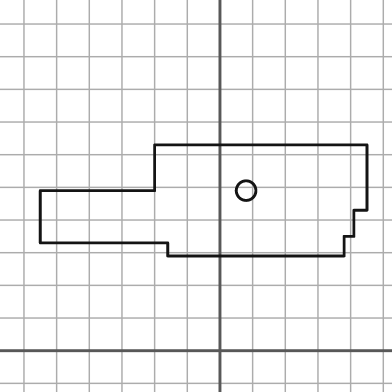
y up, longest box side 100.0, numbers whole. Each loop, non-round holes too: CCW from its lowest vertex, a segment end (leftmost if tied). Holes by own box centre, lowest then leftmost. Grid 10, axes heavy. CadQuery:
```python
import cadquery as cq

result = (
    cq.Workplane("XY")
    .moveTo(-16.0, 29.0)
    .lineTo(38.0, 29.0)
    .lineTo(38.0, 35.0)
    .lineTo(41.0, 35.0)
    .lineTo(41.0, 43.0)
    .lineTo(45.0, 43.0)
    .lineTo(45.0, 63.0)
    .lineTo(-20.0, 63.0)
    .lineTo(-20.0, 49.0)
    .lineTo(-55.0, 49.0)
    .lineTo(-55.0, 33.0)
    .lineTo(-16.0, 33.0)
    .close()
    .moveTo(8.0, 49.0)
    .circle(3.0)
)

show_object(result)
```